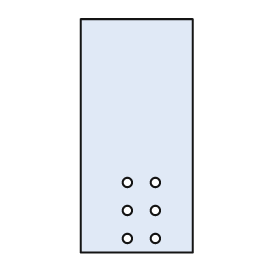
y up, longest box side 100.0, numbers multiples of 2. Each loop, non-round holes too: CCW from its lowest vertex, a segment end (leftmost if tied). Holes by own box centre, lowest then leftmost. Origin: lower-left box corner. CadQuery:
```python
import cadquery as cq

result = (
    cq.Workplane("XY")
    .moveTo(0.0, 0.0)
    .lineTo(48.0, 0.0)
    .lineTo(48.0, 100.0)
    .lineTo(0.0, 100.0)
    .close()
    .moveTo(20.0, 6.0)
    .circle(2.0)
    .moveTo(32.0, 6.0)
    .circle(2.0)
    .moveTo(20.0, 18.0)
    .circle(2.0)
    .moveTo(32.0, 18.0)
    .circle(2.0)
    .moveTo(20.0, 30.0)
    .circle(2.0)
    .moveTo(32.0, 30.0)
    .circle(2.0)
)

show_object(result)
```